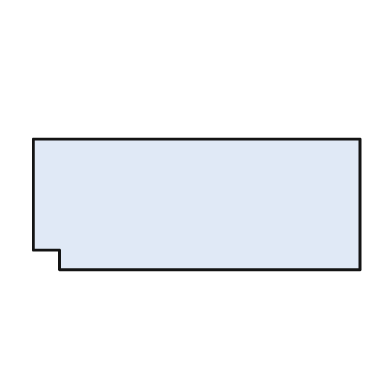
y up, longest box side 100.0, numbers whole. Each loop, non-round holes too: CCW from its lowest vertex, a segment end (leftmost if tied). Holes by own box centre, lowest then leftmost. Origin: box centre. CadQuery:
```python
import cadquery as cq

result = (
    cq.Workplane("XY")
    .moveTo(-42.0, -20.0)
    .lineTo(50.0, -20.0)
    .lineTo(50.0, 20.0)
    .lineTo(-50.0, 20.0)
    .lineTo(-50.0, -14.0)
    .lineTo(-42.0, -14.0)
    .close()
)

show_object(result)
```